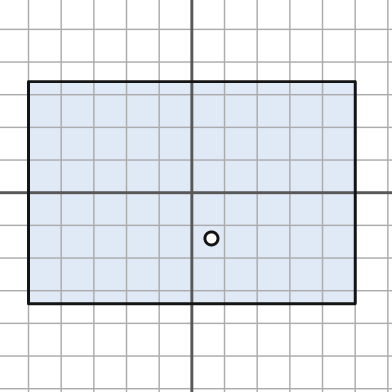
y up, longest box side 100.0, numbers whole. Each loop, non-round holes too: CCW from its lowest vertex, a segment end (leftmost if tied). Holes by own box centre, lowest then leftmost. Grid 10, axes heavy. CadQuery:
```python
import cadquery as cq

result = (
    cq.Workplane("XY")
    .moveTo(-50.0, -34.0)
    .lineTo(50.0, -34.0)
    .lineTo(50.0, 34.0)
    .lineTo(-50.0, 34.0)
    .close()
    .moveTo(6.0, -14.0)
    .circle(2.0)
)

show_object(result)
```